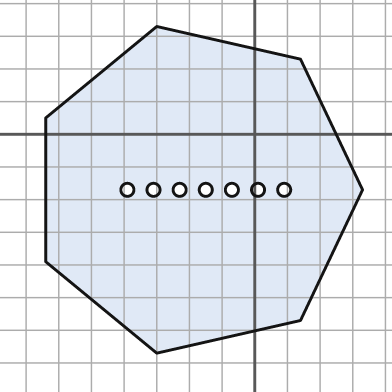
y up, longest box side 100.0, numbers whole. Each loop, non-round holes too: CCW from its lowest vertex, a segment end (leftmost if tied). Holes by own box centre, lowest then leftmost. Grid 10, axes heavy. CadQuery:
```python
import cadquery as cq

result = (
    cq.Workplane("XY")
    .moveTo(-30.0, -67.0)
    .lineTo(14.0, -57.0)
    .lineTo(33.0, -17.0)
    .lineTo(14.0, 23.0)
    .lineTo(-30.0, 33.0)
    .lineTo(-64.0, 5.0)
    .lineTo(-64.0, -39.0)
    .close()
    .moveTo(-39.0, -17.0)
    .circle(2.0)
    .moveTo(-31.0, -17.0)
    .circle(2.0)
    .moveTo(-23.0, -17.0)
    .circle(2.0)
    .moveTo(-15.0, -17.0)
    .circle(2.0)
    .moveTo(-7.0, -17.0)
    .circle(2.0)
    .moveTo(1.0, -17.0)
    .circle(2.0)
    .moveTo(9.0, -17.0)
    .circle(2.0)
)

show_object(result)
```